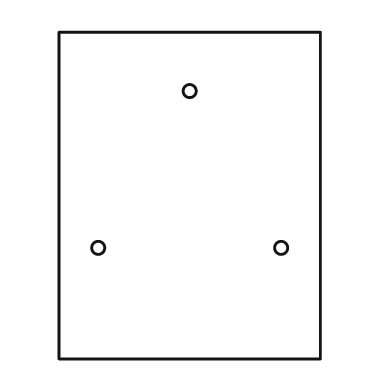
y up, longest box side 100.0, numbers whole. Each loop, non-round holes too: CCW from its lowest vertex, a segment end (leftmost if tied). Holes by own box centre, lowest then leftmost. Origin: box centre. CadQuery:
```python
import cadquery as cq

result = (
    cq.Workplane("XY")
    .moveTo(-40.0, -50.0)
    .lineTo(40.0, -50.0)
    .lineTo(40.0, 50.0)
    .lineTo(-40.0, 50.0)
    .close()
    .moveTo(-28.0, -16.0)
    .circle(2.0)
    .moveTo(28.0, -16.0)
    .circle(2.0)
    .moveTo(0.0, 32.0)
    .circle(2.0)
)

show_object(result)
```